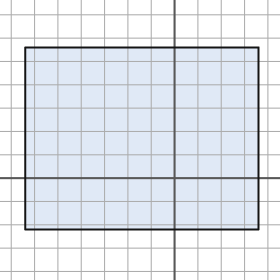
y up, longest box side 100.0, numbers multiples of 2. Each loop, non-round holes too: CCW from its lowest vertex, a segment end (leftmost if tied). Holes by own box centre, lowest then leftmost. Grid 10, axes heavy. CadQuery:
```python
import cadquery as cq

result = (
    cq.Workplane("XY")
    .moveTo(-64.0, -22.0)
    .lineTo(36.0, -22.0)
    .lineTo(36.0, 56.0)
    .lineTo(-64.0, 56.0)
    .close()
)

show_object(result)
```